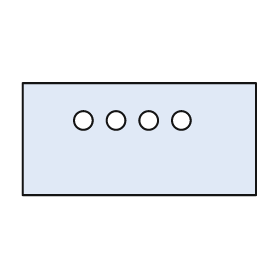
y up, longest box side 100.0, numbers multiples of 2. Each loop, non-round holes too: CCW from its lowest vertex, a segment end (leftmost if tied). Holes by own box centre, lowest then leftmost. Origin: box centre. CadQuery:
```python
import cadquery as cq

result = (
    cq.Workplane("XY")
    .moveTo(-50.0, -24.0)
    .lineTo(50.0, -24.0)
    .lineTo(50.0, 24.0)
    .lineTo(-50.0, 24.0)
    .close()
    .moveTo(-24.0, 8.0)
    .circle(4.0)
    .moveTo(-10.0, 8.0)
    .circle(4.0)
    .moveTo(4.0, 8.0)
    .circle(4.0)
    .moveTo(18.0, 8.0)
    .circle(4.0)
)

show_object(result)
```